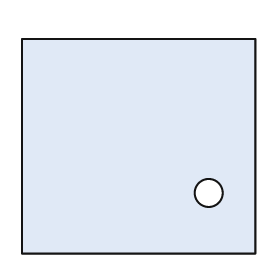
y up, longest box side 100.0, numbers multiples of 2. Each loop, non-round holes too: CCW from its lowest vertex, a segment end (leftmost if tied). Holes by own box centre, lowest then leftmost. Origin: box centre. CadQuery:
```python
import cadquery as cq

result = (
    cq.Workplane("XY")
    .moveTo(-50.0, -46.0)
    .lineTo(50.0, -46.0)
    .lineTo(50.0, 46.0)
    .lineTo(-50.0, 46.0)
    .close()
    .moveTo(30.0, -20.0)
    .circle(6.0)
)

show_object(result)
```